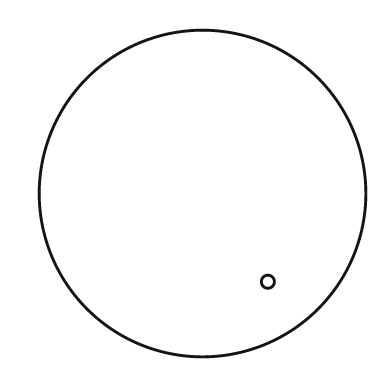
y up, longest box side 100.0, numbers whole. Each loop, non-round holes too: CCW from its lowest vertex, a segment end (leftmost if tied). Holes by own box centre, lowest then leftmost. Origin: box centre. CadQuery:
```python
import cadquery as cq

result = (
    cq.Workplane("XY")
    .moveTo(0.0, 0.0)
    .circle(50.0)
    .moveTo(20.0, -27.0)
    .circle(2.0)
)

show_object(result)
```